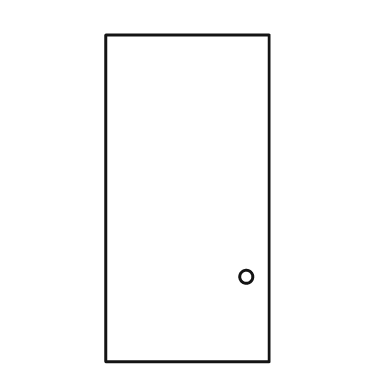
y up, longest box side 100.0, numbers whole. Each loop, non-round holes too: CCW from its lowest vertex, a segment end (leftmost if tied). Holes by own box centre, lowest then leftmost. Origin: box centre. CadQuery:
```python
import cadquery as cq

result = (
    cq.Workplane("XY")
    .moveTo(-25.0, -50.0)
    .lineTo(25.0, -50.0)
    .lineTo(25.0, 50.0)
    .lineTo(-25.0, 50.0)
    .close()
    .moveTo(18.0, -24.0)
    .circle(2.0)
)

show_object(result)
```